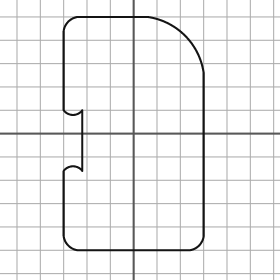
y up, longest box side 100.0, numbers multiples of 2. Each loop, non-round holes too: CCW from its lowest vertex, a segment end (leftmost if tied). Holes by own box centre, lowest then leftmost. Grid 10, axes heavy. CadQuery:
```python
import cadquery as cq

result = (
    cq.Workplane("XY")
    .moveTo(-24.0, -50.0)
    .lineTo(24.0, -50.0)
    .threePointArc((28.0, -48.0), (30.0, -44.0))
    .lineTo(30.0, 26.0)
    .threePointArc((22.0, 42.0), (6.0, 50.0))
    .lineTo(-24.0, 50.0)
    .threePointArc((-28.0, 48.0), (-30.0, 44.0))
    .lineTo(-30.0, 10.0)
    .threePointArc((-26.0, 8.0), (-22.0, 10.0))
    .lineTo(-22.0, -16.0)
    .threePointArc((-26.0, -14.0), (-30.0, -16.0))
    .lineTo(-30.0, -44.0)
    .threePointArc((-28.0, -48.0), (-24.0, -50.0))
    .close()
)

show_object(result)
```